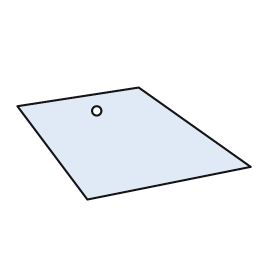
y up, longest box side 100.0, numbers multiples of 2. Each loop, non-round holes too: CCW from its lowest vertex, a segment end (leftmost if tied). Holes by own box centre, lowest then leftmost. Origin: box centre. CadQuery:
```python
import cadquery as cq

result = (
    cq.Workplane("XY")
    .moveTo(-20.0, -24.0)
    .lineTo(50.0, -10.0)
    .lineTo(2.0, 24.0)
    .lineTo(-50.0, 16.0)
    .close()
    .moveTo(-16.0, 14.0)
    .circle(2.0)
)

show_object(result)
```